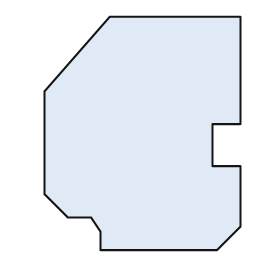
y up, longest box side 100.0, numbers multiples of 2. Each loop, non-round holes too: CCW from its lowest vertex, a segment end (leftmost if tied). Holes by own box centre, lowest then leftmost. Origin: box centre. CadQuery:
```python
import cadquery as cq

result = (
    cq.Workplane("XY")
    .moveTo(-18.0, -50.0)
    .lineTo(32.0, -50.0)
    .lineTo(42.0, -40.0)
    .lineTo(42.0, -14.0)
    .lineTo(30.0, -14.0)
    .lineTo(30.0, 4.0)
    .lineTo(42.0, 4.0)
    .lineTo(42.0, 50.0)
    .lineTo(-14.0, 50.0)
    .lineTo(-42.0, 18.0)
    .lineTo(-42.0, -26.0)
    .lineTo(-32.0, -36.0)
    .lineTo(-22.0, -36.0)
    .lineTo(-18.0, -42.0)
    .close()
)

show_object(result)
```